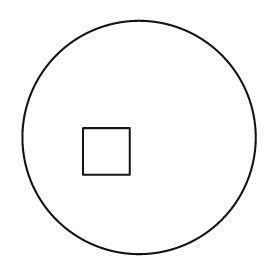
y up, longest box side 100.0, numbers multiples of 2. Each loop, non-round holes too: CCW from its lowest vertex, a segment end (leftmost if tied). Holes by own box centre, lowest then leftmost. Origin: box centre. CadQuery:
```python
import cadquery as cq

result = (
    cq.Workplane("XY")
    .moveTo(0.0, 0.0)
    .circle(50.0)
    .moveTo(-24.0, -16.0)
    .lineTo(-4.0, -16.0)
    .lineTo(-4.0, 4.0)
    .lineTo(-24.0, 4.0)
    .close()
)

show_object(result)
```